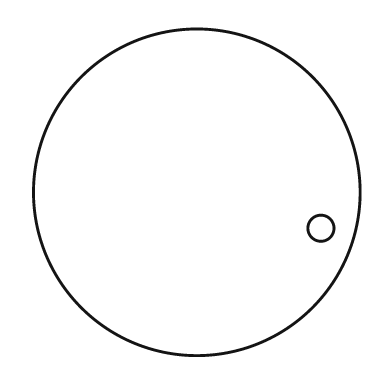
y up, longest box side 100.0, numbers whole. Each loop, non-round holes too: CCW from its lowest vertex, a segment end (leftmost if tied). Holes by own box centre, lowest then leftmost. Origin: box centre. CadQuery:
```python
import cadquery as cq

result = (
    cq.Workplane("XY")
    .moveTo(0.0, 0.0)
    .circle(50.0)
    .moveTo(38.0, -11.0)
    .circle(4.0)
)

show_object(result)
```